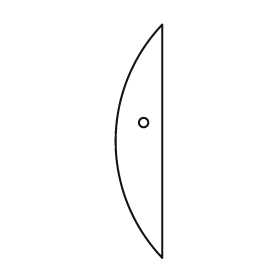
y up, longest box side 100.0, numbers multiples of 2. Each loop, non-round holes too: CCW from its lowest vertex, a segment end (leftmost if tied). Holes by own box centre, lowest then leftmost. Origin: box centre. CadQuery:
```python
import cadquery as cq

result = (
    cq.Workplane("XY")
    .moveTo(10.0, -50.0)
    .lineTo(10.0, 50.0)
    .threePointArc((-10.0, 0.0), (10.0, -50.0))
    .close()
    .moveTo(2.0, 8.0)
    .circle(2.0)
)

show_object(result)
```